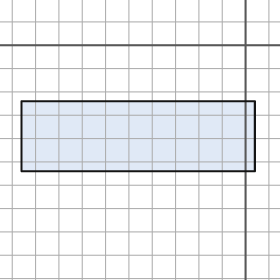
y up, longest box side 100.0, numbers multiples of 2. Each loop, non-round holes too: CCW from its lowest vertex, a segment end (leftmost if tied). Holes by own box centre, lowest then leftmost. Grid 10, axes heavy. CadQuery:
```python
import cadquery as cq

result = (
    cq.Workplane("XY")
    .moveTo(-96.0, -54.0)
    .lineTo(4.0, -54.0)
    .lineTo(4.0, -24.0)
    .lineTo(-96.0, -24.0)
    .close()
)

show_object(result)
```